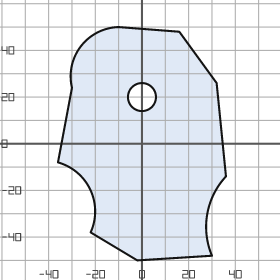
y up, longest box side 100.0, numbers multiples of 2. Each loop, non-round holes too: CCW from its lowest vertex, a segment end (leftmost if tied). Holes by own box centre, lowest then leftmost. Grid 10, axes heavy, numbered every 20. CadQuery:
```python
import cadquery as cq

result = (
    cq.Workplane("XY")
    .moveTo(-2.0, -50.0)
    .lineTo(30.0, -48.0)
    .threePointArc((28.0, -30.0), (36.0, -14.0))
    .lineTo(32.0, 26.0)
    .lineTo(16.0, 48.0)
    .lineTo(-10.0, 50.0)
    .threePointArc((-26.0, 42.0), (-30.0, 24.0))
    .lineTo(-36.0, -8.0)
    .threePointArc((-22.0, -20.0), (-22.0, -38.0))
    .close()
    .moveTo(0.0, 20.0)
    .circle(6.0)
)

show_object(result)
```